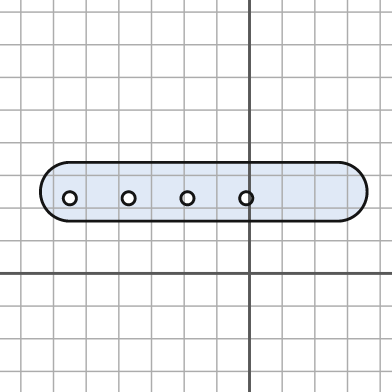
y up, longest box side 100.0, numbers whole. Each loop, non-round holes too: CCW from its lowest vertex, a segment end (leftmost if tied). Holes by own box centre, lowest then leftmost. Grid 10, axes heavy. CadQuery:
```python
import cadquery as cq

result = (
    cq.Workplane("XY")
    .moveTo(-55.0, 16.0)
    .lineTo(27.0, 16.0)
    .threePointArc((36.0, 25.0), (27.0, 34.0))
    .lineTo(-55.0, 34.0)
    .threePointArc((-64.0, 25.0), (-55.0, 16.0))
    .close()
    .moveTo(-55.0, 23.0)
    .circle(2.0)
    .moveTo(-37.0, 23.0)
    .circle(2.0)
    .moveTo(-19.0, 23.0)
    .circle(2.0)
    .moveTo(-1.0, 23.0)
    .circle(2.0)
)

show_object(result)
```